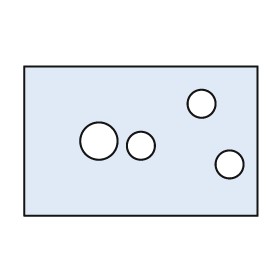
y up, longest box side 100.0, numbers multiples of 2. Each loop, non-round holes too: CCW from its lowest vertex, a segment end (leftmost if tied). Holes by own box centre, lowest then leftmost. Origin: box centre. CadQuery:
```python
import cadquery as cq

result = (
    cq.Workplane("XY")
    .moveTo(-50.0, -32.0)
    .lineTo(50.0, -32.0)
    .lineTo(50.0, 32.0)
    .lineTo(-50.0, 32.0)
    .close()
    .moveTo(38.0, -10.0)
    .circle(6.0)
    .moveTo(0.0, -2.0)
    .circle(6.0)
    .moveTo(-18.0, 0.0)
    .circle(8.0)
    .moveTo(26.0, 16.0)
    .circle(6.0)
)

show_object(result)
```